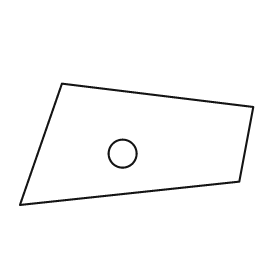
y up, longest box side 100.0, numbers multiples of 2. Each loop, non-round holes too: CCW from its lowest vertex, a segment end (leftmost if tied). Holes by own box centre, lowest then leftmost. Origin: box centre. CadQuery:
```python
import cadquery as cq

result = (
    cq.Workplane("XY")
    .moveTo(-50.0, -26.0)
    .lineTo(44.0, -16.0)
    .lineTo(50.0, 16.0)
    .lineTo(-32.0, 26.0)
    .close()
    .moveTo(-6.0, -4.0)
    .circle(6.0)
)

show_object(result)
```